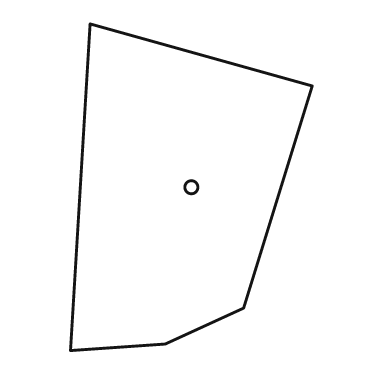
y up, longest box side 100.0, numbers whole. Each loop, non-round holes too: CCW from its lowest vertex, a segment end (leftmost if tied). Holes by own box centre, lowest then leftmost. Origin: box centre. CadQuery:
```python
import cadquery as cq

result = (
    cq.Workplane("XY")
    .moveTo(-37.0, -50.0)
    .lineTo(-8.0, -48.0)
    .lineTo(16.0, -37.0)
    .lineTo(37.0, 31.0)
    .lineTo(-31.0, 50.0)
    .close()
    .moveTo(0.0, 0.0)
    .circle(2.0)
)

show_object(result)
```